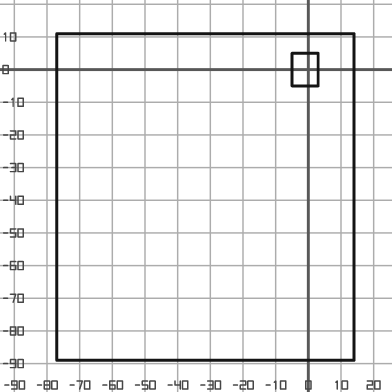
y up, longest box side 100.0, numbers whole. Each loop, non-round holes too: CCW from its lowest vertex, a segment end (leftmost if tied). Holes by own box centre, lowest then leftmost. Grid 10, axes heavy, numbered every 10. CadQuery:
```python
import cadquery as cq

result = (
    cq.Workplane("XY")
    .moveTo(-77.0, -89.0)
    .lineTo(14.0, -89.0)
    .lineTo(14.0, 11.0)
    .lineTo(-77.0, 11.0)
    .close()
    .moveTo(-5.0, -5.0)
    .lineTo(3.0, -5.0)
    .lineTo(3.0, 5.0)
    .lineTo(-5.0, 5.0)
    .close()
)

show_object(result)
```